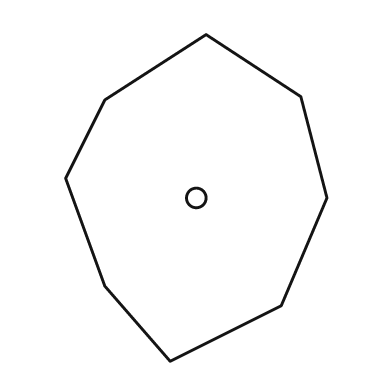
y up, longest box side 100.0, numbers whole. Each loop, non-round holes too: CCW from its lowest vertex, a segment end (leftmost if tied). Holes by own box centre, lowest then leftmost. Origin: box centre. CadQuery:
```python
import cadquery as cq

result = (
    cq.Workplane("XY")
    .moveTo(-8.0, -50.0)
    .lineTo(26.0, -33.0)
    .lineTo(40.0, 0.0)
    .lineTo(32.0, 31.0)
    .lineTo(3.0, 50.0)
    .lineTo(-28.0, 30.0)
    .lineTo(-40.0, 6.0)
    .lineTo(-28.0, -27.0)
    .close()
    .moveTo(0.0, 0.0)
    .circle(3.0)
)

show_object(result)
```